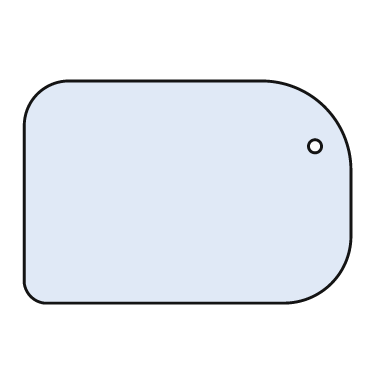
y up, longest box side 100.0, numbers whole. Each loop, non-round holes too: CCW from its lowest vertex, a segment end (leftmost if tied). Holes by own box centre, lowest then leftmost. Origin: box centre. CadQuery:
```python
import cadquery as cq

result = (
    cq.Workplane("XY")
    .moveTo(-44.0, -34.0)
    .lineTo(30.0, -34.0)
    .threePointArc((44.0, -28.0), (50.0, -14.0))
    .lineTo(50.0, 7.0)
    .threePointArc((42.0, 26.0), (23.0, 34.0))
    .lineTo(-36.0, 34.0)
    .threePointArc((-46.0, 30.0), (-50.0, 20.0))
    .lineTo(-50.0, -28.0)
    .threePointArc((-48.0, -32.0), (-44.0, -34.0))
    .close()
    .moveTo(39.0, 14.0)
    .circle(2.0)
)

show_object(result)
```